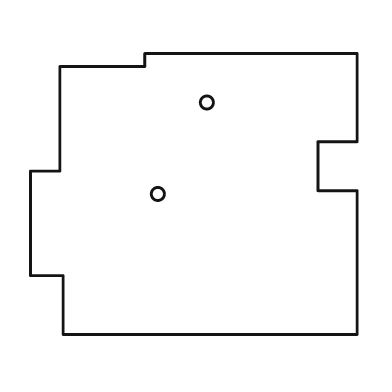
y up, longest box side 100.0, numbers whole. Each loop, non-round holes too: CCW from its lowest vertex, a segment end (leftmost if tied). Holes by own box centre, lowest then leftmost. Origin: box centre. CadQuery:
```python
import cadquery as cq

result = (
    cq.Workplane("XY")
    .moveTo(-40.0, -43.0)
    .lineTo(50.0, -43.0)
    .lineTo(50.0, 1.0)
    .lineTo(38.0, 1.0)
    .lineTo(38.0, 16.0)
    .lineTo(50.0, 16.0)
    .lineTo(50.0, 43.0)
    .lineTo(-15.0, 43.0)
    .lineTo(-15.0, 39.0)
    .lineTo(-41.0, 39.0)
    .lineTo(-41.0, 7.0)
    .lineTo(-50.0, 7.0)
    .lineTo(-50.0, -25.0)
    .lineTo(-40.0, -25.0)
    .close()
    .moveTo(-11.0, 0.0)
    .circle(2.0)
    .moveTo(4.0, 28.0)
    .circle(2.0)
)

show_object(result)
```